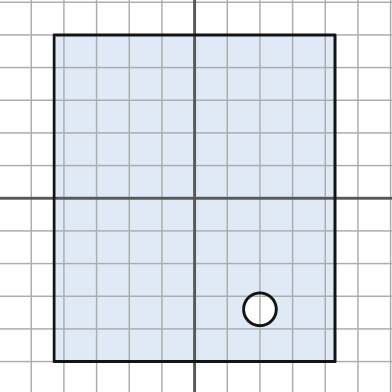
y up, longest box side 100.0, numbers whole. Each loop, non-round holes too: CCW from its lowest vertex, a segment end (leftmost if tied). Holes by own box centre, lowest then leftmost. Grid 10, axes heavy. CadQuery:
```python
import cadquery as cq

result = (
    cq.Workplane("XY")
    .moveTo(-43.0, -50.0)
    .lineTo(43.0, -50.0)
    .lineTo(43.0, 50.0)
    .lineTo(-43.0, 50.0)
    .close()
    .moveTo(20.0, -34.0)
    .circle(5.0)
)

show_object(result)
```